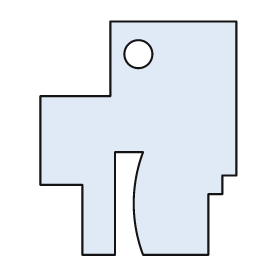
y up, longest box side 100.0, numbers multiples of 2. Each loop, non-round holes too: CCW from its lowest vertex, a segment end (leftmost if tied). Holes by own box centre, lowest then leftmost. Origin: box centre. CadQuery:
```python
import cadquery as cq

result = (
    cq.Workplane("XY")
    .moveTo(-24.0, -50.0)
    .lineTo(-10.0, -50.0)
    .lineTo(-10.0, -6.0)
    .lineTo(2.0, -6.0)
    .threePointArc((-2.0, -28.0), (2.0, -50.0))
    .lineTo(30.0, -50.0)
    .lineTo(30.0, -24.0)
    .lineTo(36.0, -24.0)
    .lineTo(36.0, -16.0)
    .lineTo(42.0, -16.0)
    .lineTo(42.0, 50.0)
    .lineTo(-12.0, 50.0)
    .lineTo(-12.0, 18.0)
    .lineTo(-42.0, 18.0)
    .lineTo(-42.0, -20.0)
    .lineTo(-24.0, -20.0)
    .close()
    .moveTo(0.0, 36.0)
    .circle(6.0)
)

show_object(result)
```